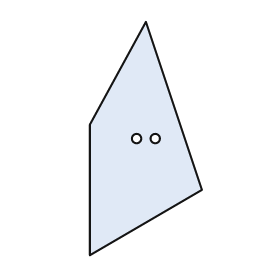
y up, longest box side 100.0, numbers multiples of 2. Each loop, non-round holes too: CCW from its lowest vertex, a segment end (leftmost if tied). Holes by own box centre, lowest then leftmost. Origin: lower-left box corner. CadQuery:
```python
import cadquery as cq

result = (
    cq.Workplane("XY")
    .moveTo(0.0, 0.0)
    .lineTo(48.0, 28.0)
    .lineTo(24.0, 100.0)
    .lineTo(0.0, 56.0)
    .close()
    .moveTo(20.0, 50.0)
    .circle(2.0)
    .moveTo(28.0, 50.0)
    .circle(2.0)
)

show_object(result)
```